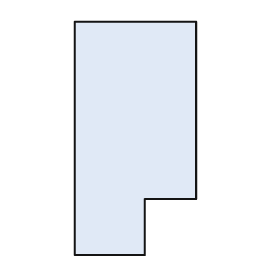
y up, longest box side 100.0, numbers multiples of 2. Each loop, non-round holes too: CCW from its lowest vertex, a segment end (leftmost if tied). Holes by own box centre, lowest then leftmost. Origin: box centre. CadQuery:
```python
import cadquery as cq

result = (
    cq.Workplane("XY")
    .moveTo(-26.0, -50.0)
    .lineTo(4.0, -50.0)
    .lineTo(4.0, -26.0)
    .lineTo(26.0, -26.0)
    .lineTo(26.0, 50.0)
    .lineTo(-26.0, 50.0)
    .close()
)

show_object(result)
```